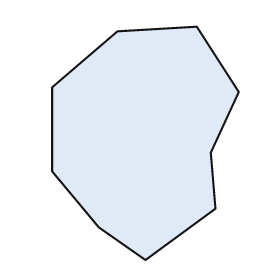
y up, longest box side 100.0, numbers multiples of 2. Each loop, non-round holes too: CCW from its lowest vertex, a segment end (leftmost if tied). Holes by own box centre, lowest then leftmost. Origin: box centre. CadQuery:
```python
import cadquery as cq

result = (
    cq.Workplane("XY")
    .moveTo(0.0, -50.0)
    .lineTo(30.0, -28.0)
    .lineTo(28.0, -4.0)
    .lineTo(40.0, 22.0)
    .lineTo(22.0, 50.0)
    .lineTo(-12.0, 48.0)
    .lineTo(-40.0, 24.0)
    .lineTo(-40.0, -12.0)
    .lineTo(-20.0, -36.0)
    .close()
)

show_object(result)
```